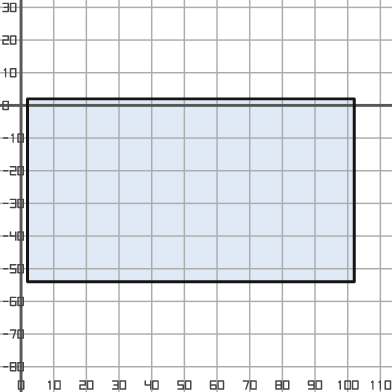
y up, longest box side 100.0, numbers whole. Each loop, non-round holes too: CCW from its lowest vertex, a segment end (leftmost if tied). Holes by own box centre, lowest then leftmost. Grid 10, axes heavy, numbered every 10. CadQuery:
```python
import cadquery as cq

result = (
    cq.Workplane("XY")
    .moveTo(2.0, -54.0)
    .lineTo(102.0, -54.0)
    .lineTo(102.0, 2.0)
    .lineTo(2.0, 2.0)
    .close()
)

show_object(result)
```